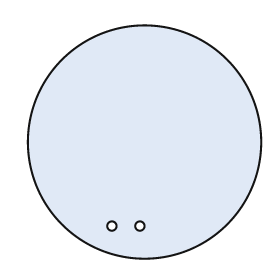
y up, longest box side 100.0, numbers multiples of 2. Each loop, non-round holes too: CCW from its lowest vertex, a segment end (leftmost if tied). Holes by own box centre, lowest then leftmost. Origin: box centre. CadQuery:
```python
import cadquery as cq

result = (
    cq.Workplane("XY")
    .moveTo(0.0, 0.0)
    .circle(50.0)
    .moveTo(-14.0, -36.0)
    .circle(2.0)
    .moveTo(-2.0, -36.0)
    .circle(2.0)
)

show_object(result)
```